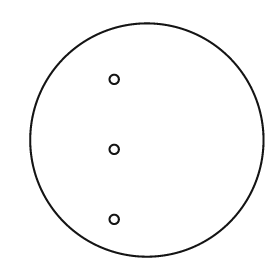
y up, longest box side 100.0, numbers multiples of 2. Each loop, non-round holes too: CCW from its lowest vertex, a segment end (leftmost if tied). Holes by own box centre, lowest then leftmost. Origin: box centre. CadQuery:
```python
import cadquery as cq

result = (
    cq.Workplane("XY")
    .moveTo(0.0, 0.0)
    .circle(50.0)
    .moveTo(-14.0, -34.0)
    .circle(2.0)
    .moveTo(-14.0, -4.0)
    .circle(2.0)
    .moveTo(-14.0, 26.0)
    .circle(2.0)
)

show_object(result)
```